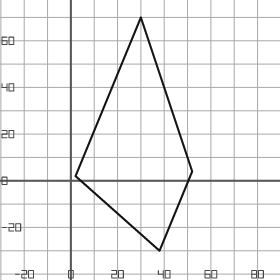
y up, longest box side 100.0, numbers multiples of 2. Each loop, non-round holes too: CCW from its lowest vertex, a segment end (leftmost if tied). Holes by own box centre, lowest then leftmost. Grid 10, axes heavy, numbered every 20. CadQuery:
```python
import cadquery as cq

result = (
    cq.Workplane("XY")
    .moveTo(38.0, -30.0)
    .lineTo(52.0, 4.0)
    .lineTo(30.0, 70.0)
    .lineTo(2.0, 2.0)
    .close()
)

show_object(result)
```